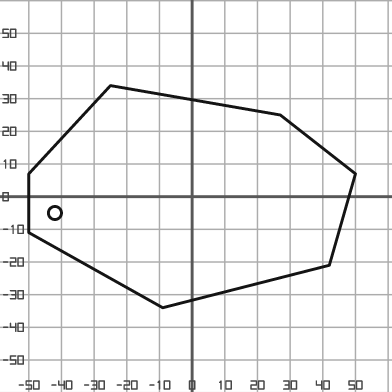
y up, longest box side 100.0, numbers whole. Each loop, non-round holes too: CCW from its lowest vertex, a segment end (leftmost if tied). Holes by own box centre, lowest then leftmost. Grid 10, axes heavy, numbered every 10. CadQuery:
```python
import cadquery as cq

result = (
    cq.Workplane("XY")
    .moveTo(-9.0, -34.0)
    .lineTo(42.0, -21.0)
    .lineTo(50.0, 7.0)
    .lineTo(27.0, 25.0)
    .lineTo(-25.0, 34.0)
    .lineTo(-50.0, 7.0)
    .lineTo(-50.0, -11.0)
    .close()
    .moveTo(-42.0, -5.0)
    .circle(2.0)
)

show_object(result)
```